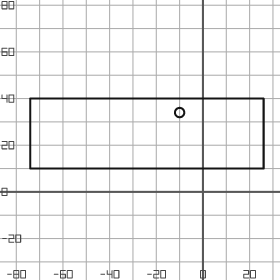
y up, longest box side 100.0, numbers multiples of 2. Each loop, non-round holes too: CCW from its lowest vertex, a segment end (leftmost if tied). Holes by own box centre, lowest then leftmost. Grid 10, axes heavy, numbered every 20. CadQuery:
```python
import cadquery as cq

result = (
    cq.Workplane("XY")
    .moveTo(-74.0, 10.0)
    .lineTo(26.0, 10.0)
    .lineTo(26.0, 40.0)
    .lineTo(-74.0, 40.0)
    .close()
    .moveTo(-10.0, 34.0)
    .circle(2.0)
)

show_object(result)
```